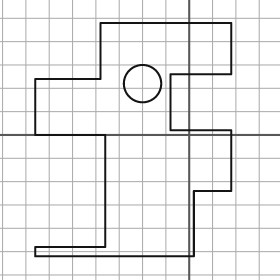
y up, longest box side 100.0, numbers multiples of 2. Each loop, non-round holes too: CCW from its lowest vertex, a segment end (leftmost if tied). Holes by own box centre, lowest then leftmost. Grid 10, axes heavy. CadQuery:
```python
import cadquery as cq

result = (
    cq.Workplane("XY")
    .moveTo(-66.0, -52.0)
    .lineTo(2.0, -52.0)
    .lineTo(2.0, -24.0)
    .lineTo(18.0, -24.0)
    .lineTo(18.0, 2.0)
    .lineTo(-8.0, 2.0)
    .lineTo(-8.0, 26.0)
    .lineTo(18.0, 26.0)
    .lineTo(18.0, 48.0)
    .lineTo(-38.0, 48.0)
    .lineTo(-38.0, 24.0)
    .lineTo(-66.0, 24.0)
    .lineTo(-66.0, 0.0)
    .lineTo(-36.0, 0.0)
    .lineTo(-36.0, -48.0)
    .lineTo(-66.0, -48.0)
    .close()
    .moveTo(-20.0, 22.0)
    .circle(8.0)
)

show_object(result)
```